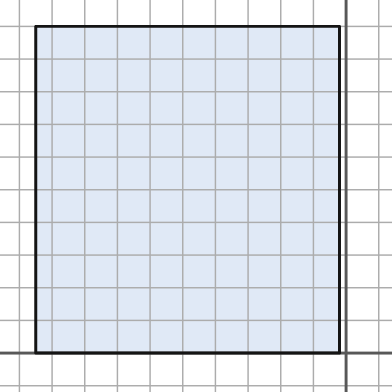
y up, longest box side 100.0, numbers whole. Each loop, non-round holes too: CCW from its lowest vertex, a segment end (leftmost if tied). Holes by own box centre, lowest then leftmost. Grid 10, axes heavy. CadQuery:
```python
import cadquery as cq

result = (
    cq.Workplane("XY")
    .moveTo(-95.0, 0.0)
    .lineTo(-2.0, 0.0)
    .lineTo(-2.0, 100.0)
    .lineTo(-95.0, 100.0)
    .close()
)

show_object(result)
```